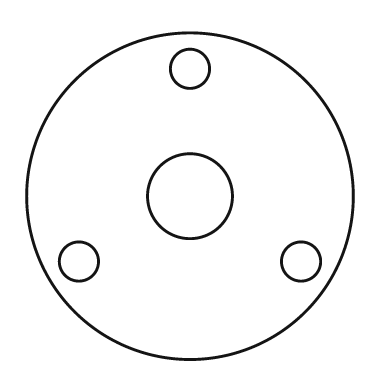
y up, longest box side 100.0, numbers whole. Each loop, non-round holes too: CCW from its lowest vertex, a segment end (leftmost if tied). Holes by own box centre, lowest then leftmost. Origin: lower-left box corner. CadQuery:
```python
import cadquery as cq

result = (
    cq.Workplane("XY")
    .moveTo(50.0, 50.0)
    .circle(50.0)
    .moveTo(16.0, 30.0)
    .circle(6.0)
    .moveTo(84.0, 30.0)
    .circle(6.0)
    .moveTo(50.0, 50.0)
    .circle(13.0)
    .moveTo(50.0, 89.0)
    .circle(6.0)
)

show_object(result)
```